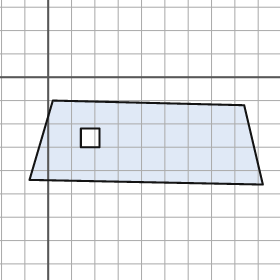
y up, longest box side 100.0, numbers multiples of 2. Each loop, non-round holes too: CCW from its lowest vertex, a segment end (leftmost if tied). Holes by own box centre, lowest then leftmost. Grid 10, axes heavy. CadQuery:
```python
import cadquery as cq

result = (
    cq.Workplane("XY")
    .moveTo(92.0, -46.0)
    .lineTo(84.0, -12.0)
    .lineTo(2.0, -10.0)
    .lineTo(-8.0, -44.0)
    .close()
    .moveTo(14.0, -30.0)
    .lineTo(22.0, -30.0)
    .lineTo(22.0, -22.0)
    .lineTo(14.0, -22.0)
    .close()
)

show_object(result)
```